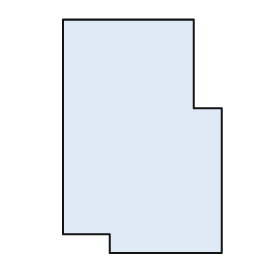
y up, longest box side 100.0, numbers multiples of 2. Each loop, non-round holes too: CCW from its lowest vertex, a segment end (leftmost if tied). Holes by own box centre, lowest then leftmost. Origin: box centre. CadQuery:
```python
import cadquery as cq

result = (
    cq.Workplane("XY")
    .moveTo(-14.0, -50.0)
    .lineTo(34.0, -50.0)
    .lineTo(34.0, 12.0)
    .lineTo(22.0, 12.0)
    .lineTo(22.0, 50.0)
    .lineTo(-34.0, 50.0)
    .lineTo(-34.0, -42.0)
    .lineTo(-14.0, -42.0)
    .close()
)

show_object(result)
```